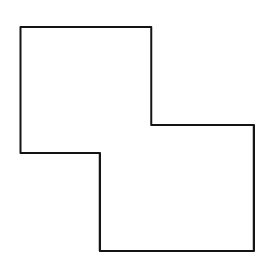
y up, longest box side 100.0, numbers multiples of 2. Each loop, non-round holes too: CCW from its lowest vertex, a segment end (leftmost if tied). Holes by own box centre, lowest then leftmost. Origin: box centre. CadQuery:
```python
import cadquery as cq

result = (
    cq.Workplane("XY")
    .moveTo(-16.0, -48.0)
    .lineTo(50.0, -48.0)
    .lineTo(50.0, 6.0)
    .lineTo(6.0, 6.0)
    .lineTo(6.0, 48.0)
    .lineTo(-50.0, 48.0)
    .lineTo(-50.0, -6.0)
    .lineTo(-16.0, -6.0)
    .close()
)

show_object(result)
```